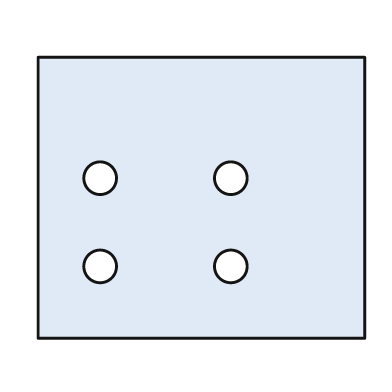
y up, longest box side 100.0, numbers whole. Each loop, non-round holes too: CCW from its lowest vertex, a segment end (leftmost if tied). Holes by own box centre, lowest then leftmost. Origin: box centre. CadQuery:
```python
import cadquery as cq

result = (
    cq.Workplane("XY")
    .moveTo(-50.0, -43.0)
    .lineTo(50.0, -43.0)
    .lineTo(50.0, 43.0)
    .lineTo(-50.0, 43.0)
    .close()
    .moveTo(-31.0, -21.0)
    .circle(5.0)
    .moveTo(9.0, -21.0)
    .circle(5.0)
    .moveTo(-31.0, 6.0)
    .circle(5.0)
    .moveTo(9.0, 6.0)
    .circle(5.0)
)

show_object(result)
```